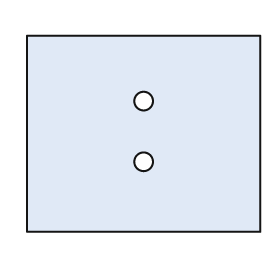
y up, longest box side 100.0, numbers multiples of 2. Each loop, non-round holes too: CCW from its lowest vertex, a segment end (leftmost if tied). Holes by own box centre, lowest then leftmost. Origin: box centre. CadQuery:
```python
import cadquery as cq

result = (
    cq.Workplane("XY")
    .moveTo(-50.0, -42.0)
    .lineTo(50.0, -42.0)
    .lineTo(50.0, 42.0)
    .lineTo(-50.0, 42.0)
    .close()
    .moveTo(0.0, -12.0)
    .circle(4.0)
    .moveTo(0.0, 14.0)
    .circle(4.0)
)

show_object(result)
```